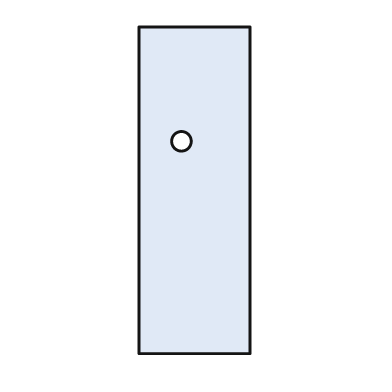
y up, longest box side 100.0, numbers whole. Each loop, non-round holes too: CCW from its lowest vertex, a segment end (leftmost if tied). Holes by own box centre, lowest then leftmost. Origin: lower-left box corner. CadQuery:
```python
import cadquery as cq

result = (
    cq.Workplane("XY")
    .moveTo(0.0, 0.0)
    .lineTo(34.0, 0.0)
    .lineTo(34.0, 100.0)
    .lineTo(0.0, 100.0)
    .close()
    .moveTo(13.0, 65.0)
    .circle(3.0)
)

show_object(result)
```